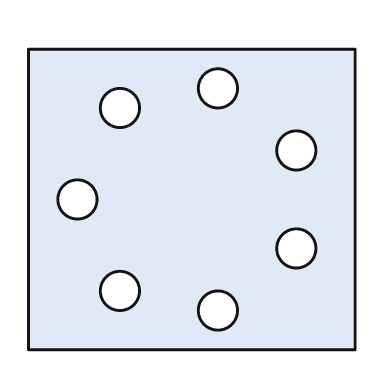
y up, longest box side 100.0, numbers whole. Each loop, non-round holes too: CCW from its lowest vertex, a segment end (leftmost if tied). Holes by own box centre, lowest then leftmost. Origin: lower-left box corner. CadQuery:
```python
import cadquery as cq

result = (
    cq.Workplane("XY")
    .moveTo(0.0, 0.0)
    .lineTo(100.0, 0.0)
    .lineTo(100.0, 92.0)
    .lineTo(0.0, 92.0)
    .close()
    .moveTo(58.0, 12.0)
    .circle(6.0)
    .moveTo(28.0, 18.0)
    .circle(6.0)
    .moveTo(82.0, 31.0)
    .circle(6.0)
    .moveTo(15.0, 46.0)
    .circle(6.0)
    .moveTo(82.0, 61.0)
    .circle(6.0)
    .moveTo(28.0, 74.0)
    .circle(6.0)
    .moveTo(58.0, 80.0)
    .circle(6.0)
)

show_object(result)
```